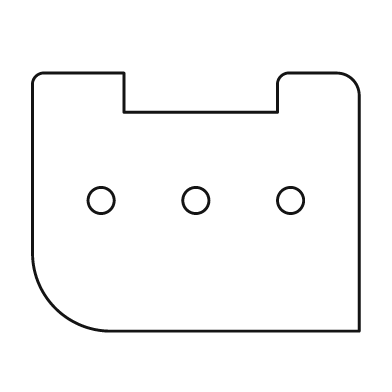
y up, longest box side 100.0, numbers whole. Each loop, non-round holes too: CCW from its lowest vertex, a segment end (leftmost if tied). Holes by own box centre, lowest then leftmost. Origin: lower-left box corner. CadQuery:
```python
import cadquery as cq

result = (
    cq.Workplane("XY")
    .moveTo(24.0, 0.0)
    .lineTo(100.0, 0.0)
    .lineTo(100.0, 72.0)
    .threePointArc((98.0, 77.0), (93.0, 79.0))
    .lineTo(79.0, 79.0)
    .threePointArc((76.0, 78.0), (75.0, 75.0))
    .lineTo(75.0, 67.0)
    .lineTo(28.0, 67.0)
    .lineTo(28.0, 79.0)
    .lineTo(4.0, 79.0)
    .threePointArc((1.0, 78.0), (0.0, 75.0))
    .lineTo(0.0, 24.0)
    .threePointArc((7.0, 7.0), (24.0, 0.0))
    .close()
    .moveTo(21.0, 40.0)
    .circle(4.0)
    .moveTo(50.0, 40.0)
    .circle(4.0)
    .moveTo(79.0, 40.0)
    .circle(4.0)
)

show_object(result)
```